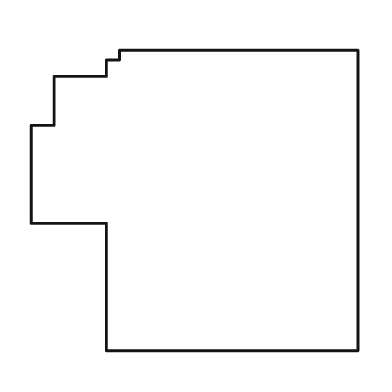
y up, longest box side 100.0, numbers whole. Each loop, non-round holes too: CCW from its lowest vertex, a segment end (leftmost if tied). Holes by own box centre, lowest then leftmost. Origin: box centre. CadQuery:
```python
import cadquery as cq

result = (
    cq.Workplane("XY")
    .moveTo(-27.0, -46.0)
    .lineTo(50.0, -46.0)
    .lineTo(50.0, 46.0)
    .lineTo(-23.0, 46.0)
    .lineTo(-23.0, 43.0)
    .lineTo(-27.0, 43.0)
    .lineTo(-27.0, 38.0)
    .lineTo(-43.0, 38.0)
    .lineTo(-43.0, 23.0)
    .lineTo(-50.0, 23.0)
    .lineTo(-50.0, -7.0)
    .lineTo(-27.0, -7.0)
    .close()
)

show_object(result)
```